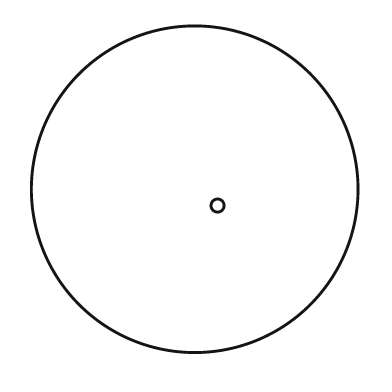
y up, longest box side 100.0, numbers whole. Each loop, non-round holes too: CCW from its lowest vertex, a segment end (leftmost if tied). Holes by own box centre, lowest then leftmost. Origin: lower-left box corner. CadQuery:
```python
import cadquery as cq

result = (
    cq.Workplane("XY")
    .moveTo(50.0, 50.0)
    .circle(50.0)
    .moveTo(57.0, 45.0)
    .circle(2.0)
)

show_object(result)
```